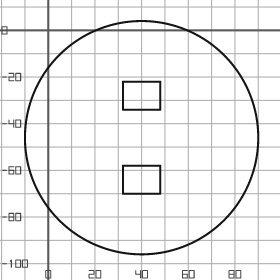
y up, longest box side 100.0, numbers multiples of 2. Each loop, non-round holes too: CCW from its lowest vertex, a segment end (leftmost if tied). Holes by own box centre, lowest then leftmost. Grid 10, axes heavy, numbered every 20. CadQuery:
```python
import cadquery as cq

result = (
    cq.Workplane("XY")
    .moveTo(40.0, -46.0)
    .circle(50.0)
    .moveTo(32.0, -70.0)
    .lineTo(48.0, -70.0)
    .lineTo(48.0, -58.0)
    .lineTo(32.0, -58.0)
    .close()
    .moveTo(32.0, -34.0)
    .lineTo(48.0, -34.0)
    .lineTo(48.0, -22.0)
    .lineTo(32.0, -22.0)
    .close()
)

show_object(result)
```